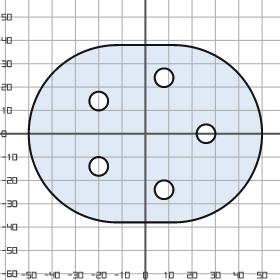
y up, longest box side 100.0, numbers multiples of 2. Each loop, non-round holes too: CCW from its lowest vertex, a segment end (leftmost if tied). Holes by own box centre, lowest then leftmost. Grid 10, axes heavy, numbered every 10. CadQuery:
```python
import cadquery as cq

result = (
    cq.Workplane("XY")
    .moveTo(-12.0, -38.0)
    .lineTo(12.0, -38.0)
    .threePointArc((50.0, 0.0), (12.0, 38.0))
    .lineTo(-12.0, 38.0)
    .threePointArc((-50.0, 0.0), (-12.0, -38.0))
    .close()
    .moveTo(8.0, -24.0)
    .circle(4.0)
    .moveTo(-20.0, -14.0)
    .circle(4.0)
    .moveTo(26.0, 0.0)
    .circle(4.0)
    .moveTo(-20.0, 14.0)
    .circle(4.0)
    .moveTo(8.0, 24.0)
    .circle(4.0)
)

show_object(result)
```